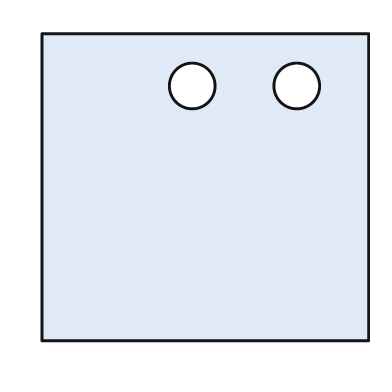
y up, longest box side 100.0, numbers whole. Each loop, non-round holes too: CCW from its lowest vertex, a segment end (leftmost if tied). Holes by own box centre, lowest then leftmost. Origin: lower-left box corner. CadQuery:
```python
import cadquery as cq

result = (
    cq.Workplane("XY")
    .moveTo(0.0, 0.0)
    .lineTo(100.0, 0.0)
    .lineTo(100.0, 94.0)
    .lineTo(0.0, 94.0)
    .close()
    .moveTo(46.0, 78.0)
    .circle(7.0)
    .moveTo(78.0, 78.0)
    .circle(7.0)
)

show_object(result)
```